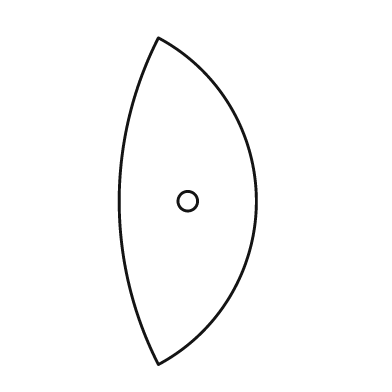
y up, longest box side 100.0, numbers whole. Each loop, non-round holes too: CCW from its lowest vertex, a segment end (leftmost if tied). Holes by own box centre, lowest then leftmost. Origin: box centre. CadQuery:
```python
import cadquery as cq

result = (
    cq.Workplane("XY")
    .moveTo(-9.0, -50.0)
    .threePointArc((21.0, 0.0), (-9.0, 50.0))
    .threePointArc((-21.0, 0.0), (-9.0, -50.0))
    .close()
    .moveTo(0.0, 0.0)
    .circle(3.0)
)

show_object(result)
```